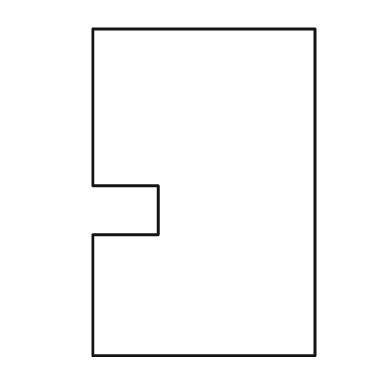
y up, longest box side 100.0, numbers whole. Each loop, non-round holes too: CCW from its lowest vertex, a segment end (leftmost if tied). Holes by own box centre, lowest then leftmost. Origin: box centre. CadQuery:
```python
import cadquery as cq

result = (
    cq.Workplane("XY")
    .moveTo(-34.0, -50.0)
    .lineTo(34.0, -50.0)
    .lineTo(34.0, 50.0)
    .lineTo(-34.0, 50.0)
    .lineTo(-34.0, 2.0)
    .lineTo(-14.0, 2.0)
    .lineTo(-14.0, -13.0)
    .lineTo(-34.0, -13.0)
    .close()
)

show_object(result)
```